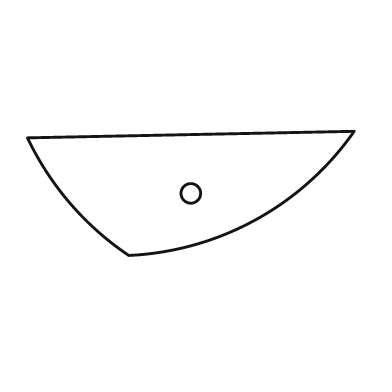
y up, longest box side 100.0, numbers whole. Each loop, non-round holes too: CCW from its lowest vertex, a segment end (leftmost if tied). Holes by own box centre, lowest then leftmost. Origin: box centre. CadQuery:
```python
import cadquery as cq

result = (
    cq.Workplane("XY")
    .moveTo(-19.0, -19.0)
    .threePointArc((20.0, -8.0), (50.0, 19.0))
    .lineTo(-50.0, 17.0)
    .threePointArc((-37.0, -3.0), (-19.0, -19.0))
    .close()
    .moveTo(0.0, 0.0)
    .circle(3.0)
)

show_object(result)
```